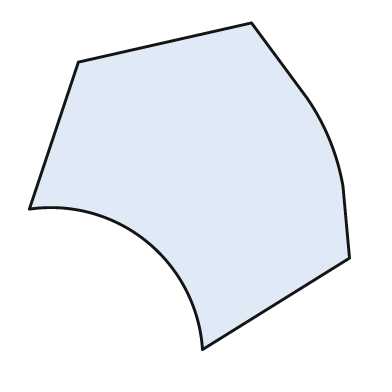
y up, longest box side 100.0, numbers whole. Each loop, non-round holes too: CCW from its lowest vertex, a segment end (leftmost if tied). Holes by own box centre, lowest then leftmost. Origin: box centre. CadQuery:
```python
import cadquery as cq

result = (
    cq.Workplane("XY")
    .moveTo(4.0, -50.0)
    .lineTo(49.0, -22.0)
    .lineTo(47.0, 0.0)
    .threePointArc((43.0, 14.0), (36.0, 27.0))
    .lineTo(19.0, 50.0)
    .lineTo(-34.0, 38.0)
    .lineTo(-49.0, -7.0)
    .threePointArc((-13.0, -17.0), (4.0, -50.0))
    .close()
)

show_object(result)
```